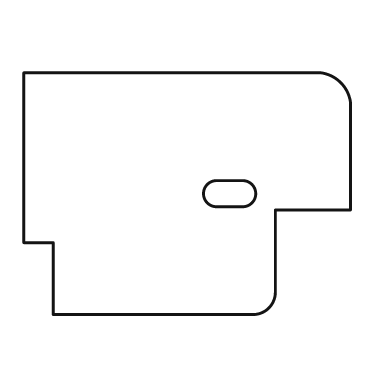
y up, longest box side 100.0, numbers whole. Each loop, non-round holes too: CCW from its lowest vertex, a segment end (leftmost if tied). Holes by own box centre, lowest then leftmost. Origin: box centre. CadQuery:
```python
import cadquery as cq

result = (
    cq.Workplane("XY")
    .moveTo(-41.0, -37.0)
    .lineTo(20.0, -37.0)
    .threePointArc((25.0, -35.0), (27.0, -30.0))
    .lineTo(27.0, -5.0)
    .lineTo(50.0, -5.0)
    .lineTo(50.0, 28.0)
    .threePointArc((47.0, 34.0), (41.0, 37.0))
    .lineTo(-50.0, 37.0)
    .lineTo(-50.0, -15.0)
    .lineTo(-41.0, -15.0)
    .close()
    .moveTo(9.0, -4.0)
    .lineTo(17.0, -4.0)
    .threePointArc((21.0, 0.0), (17.0, 4.0))
    .lineTo(9.0, 4.0)
    .threePointArc((5.0, 0.0), (9.0, -4.0))
    .close()
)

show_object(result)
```